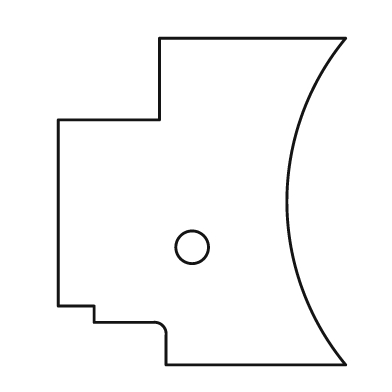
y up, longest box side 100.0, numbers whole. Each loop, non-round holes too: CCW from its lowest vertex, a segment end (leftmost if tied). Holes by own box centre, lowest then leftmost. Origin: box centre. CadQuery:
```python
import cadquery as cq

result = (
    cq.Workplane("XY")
    .moveTo(-11.0, -50.0)
    .lineTo(44.0, -50.0)
    .threePointArc((26.0, 0.0), (44.0, 50.0))
    .lineTo(-13.0, 50.0)
    .lineTo(-13.0, 25.0)
    .lineTo(-44.0, 25.0)
    .lineTo(-44.0, -32.0)
    .lineTo(-33.0, -32.0)
    .lineTo(-33.0, -37.0)
    .lineTo(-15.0, -37.0)
    .threePointArc((-12.0, -38.0), (-11.0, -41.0))
    .close()
    .moveTo(-3.0, -14.0)
    .circle(5.0)
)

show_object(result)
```